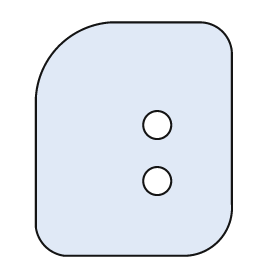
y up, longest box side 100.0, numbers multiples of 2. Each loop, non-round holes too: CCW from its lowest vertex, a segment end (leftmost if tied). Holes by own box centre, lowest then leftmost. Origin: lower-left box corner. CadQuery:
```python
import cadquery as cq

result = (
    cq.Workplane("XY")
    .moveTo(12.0, 0.0)
    .lineTo(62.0, 0.0)
    .threePointArc((78.0, 6.0), (84.0, 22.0))
    .lineTo(84.0, 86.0)
    .threePointArc((80.0, 96.0), (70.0, 100.0))
    .lineTo(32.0, 100.0)
    .threePointArc((10.0, 90.0), (0.0, 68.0))
    .lineTo(0.0, 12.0)
    .threePointArc((4.0, 4.0), (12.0, 0.0))
    .close()
    .moveTo(52.0, 32.0)
    .circle(6.0)
    .moveTo(52.0, 56.0)
    .circle(6.0)
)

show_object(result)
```